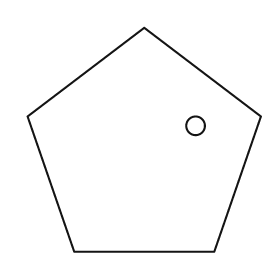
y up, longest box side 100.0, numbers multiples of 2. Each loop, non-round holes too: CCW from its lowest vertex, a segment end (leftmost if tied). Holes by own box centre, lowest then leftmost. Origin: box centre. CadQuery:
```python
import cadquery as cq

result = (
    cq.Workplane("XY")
    .moveTo(-30.0, -48.0)
    .lineTo(30.0, -48.0)
    .lineTo(50.0, 10.0)
    .lineTo(0.0, 48.0)
    .lineTo(-50.0, 10.0)
    .close()
    .moveTo(22.0, 6.0)
    .circle(4.0)
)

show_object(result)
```